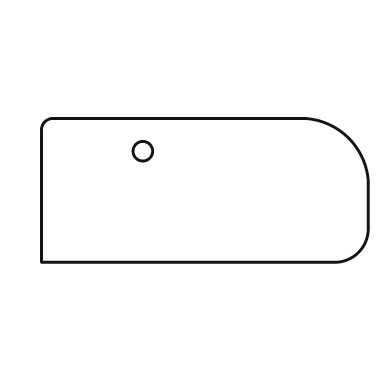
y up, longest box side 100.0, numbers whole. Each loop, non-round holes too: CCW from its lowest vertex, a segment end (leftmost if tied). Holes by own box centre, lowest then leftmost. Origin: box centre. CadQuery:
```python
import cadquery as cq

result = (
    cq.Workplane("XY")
    .moveTo(-50.0, -22.0)
    .lineTo(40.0, -22.0)
    .threePointArc((47.0, -19.0), (50.0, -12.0))
    .lineTo(50.0, 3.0)
    .threePointArc((44.0, 16.0), (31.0, 22.0))
    .lineTo(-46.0, 22.0)
    .threePointArc((-49.0, 21.0), (-50.0, 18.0))
    .close()
    .moveTo(-19.0, 12.0)
    .circle(3.0)
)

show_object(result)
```